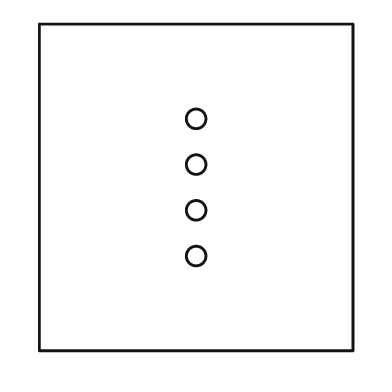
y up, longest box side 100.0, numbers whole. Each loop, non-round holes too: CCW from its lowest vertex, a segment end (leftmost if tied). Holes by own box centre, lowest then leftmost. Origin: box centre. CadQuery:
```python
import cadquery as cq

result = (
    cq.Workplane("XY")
    .moveTo(-48.0, -50.0)
    .lineTo(48.0, -50.0)
    .lineTo(48.0, 50.0)
    .lineTo(-48.0, 50.0)
    .close()
    .moveTo(0.0, -21.0)
    .circle(3.0)
    .moveTo(0.0, -7.0)
    .circle(3.0)
    .moveTo(0.0, 7.0)
    .circle(3.0)
    .moveTo(0.0, 21.0)
    .circle(3.0)
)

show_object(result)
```